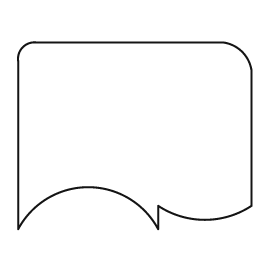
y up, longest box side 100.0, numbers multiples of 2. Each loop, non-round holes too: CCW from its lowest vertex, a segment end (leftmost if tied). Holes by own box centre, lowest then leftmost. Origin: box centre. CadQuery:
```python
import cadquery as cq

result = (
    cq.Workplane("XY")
    .moveTo(-50.0, -40.0)
    .threePointArc((-20.0, -22.0), (10.0, -40.0))
    .lineTo(10.0, -30.0)
    .threePointArc((30.0, -36.0), (50.0, -30.0))
    .lineTo(50.0, 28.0)
    .threePointArc((46.0, 36.0), (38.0, 40.0))
    .lineTo(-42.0, 40.0)
    .threePointArc((-48.0, 38.0), (-50.0, 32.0))
    .close()
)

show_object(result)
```